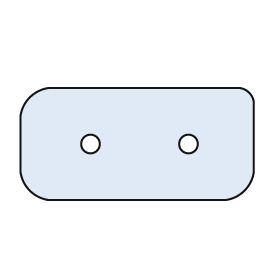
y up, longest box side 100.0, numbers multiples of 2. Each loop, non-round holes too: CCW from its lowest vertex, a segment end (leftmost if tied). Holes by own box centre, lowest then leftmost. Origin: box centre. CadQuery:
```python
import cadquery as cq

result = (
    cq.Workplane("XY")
    .moveTo(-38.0, -24.0)
    .lineTo(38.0, -24.0)
    .threePointArc((46.0, -20.0), (50.0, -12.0))
    .lineTo(50.0, 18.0)
    .threePointArc((48.0, 22.0), (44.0, 24.0))
    .lineTo(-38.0, 24.0)
    .threePointArc((-46.0, 20.0), (-50.0, 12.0))
    .lineTo(-50.0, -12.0)
    .threePointArc((-46.0, -20.0), (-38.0, -24.0))
    .close()
    .moveTo(-20.0, 0.0)
    .circle(4.0)
    .moveTo(22.0, 0.0)
    .circle(4.0)
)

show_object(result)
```